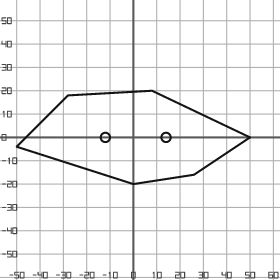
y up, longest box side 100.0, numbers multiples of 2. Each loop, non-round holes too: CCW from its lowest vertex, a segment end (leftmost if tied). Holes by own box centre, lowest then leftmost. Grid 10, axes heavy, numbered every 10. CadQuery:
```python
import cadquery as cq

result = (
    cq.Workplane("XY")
    .moveTo(0.0, -20.0)
    .lineTo(26.0, -16.0)
    .lineTo(50.0, 0.0)
    .lineTo(8.0, 20.0)
    .lineTo(-28.0, 18.0)
    .lineTo(-50.0, -4.0)
    .close()
    .moveTo(-12.0, 0.0)
    .circle(2.0)
    .moveTo(14.0, 0.0)
    .circle(2.0)
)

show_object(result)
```